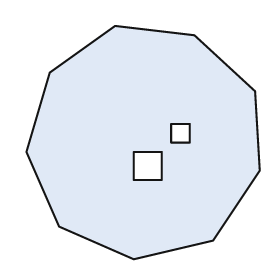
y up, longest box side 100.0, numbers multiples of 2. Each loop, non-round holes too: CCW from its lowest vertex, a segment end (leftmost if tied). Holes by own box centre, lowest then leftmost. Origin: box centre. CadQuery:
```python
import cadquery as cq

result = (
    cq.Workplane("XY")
    .moveTo(-4.0, -50.0)
    .lineTo(30.0, -42.0)
    .lineTo(50.0, -12.0)
    .lineTo(48.0, 22.0)
    .lineTo(22.0, 46.0)
    .lineTo(-12.0, 50.0)
    .lineTo(-40.0, 30.0)
    .lineTo(-50.0, -4.0)
    .lineTo(-36.0, -36.0)
    .close()
    .moveTo(-4.0, -16.0)
    .lineTo(8.0, -16.0)
    .lineTo(8.0, -4.0)
    .lineTo(-4.0, -4.0)
    .close()
    .moveTo(12.0, 0.0)
    .lineTo(20.0, 0.0)
    .lineTo(20.0, 8.0)
    .lineTo(12.0, 8.0)
    .close()
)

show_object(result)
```